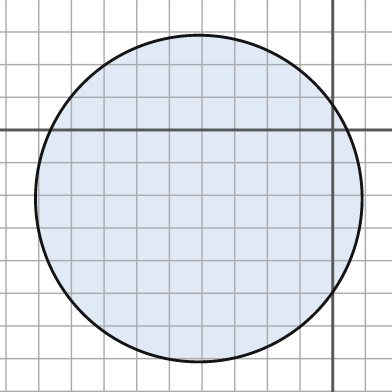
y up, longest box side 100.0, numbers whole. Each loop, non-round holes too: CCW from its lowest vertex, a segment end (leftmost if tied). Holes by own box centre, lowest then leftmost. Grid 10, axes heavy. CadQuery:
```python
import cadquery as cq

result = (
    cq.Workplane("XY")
    .moveTo(-41.0, -21.0)
    .circle(50.0)
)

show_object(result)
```